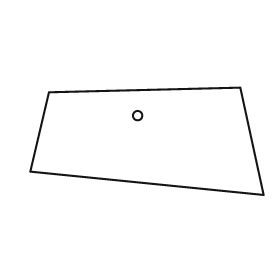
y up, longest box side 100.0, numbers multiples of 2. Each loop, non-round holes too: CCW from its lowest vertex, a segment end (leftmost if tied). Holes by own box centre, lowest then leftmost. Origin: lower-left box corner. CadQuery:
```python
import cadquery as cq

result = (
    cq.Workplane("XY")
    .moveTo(100.0, 0.0)
    .lineTo(90.0, 46.0)
    .lineTo(8.0, 44.0)
    .lineTo(0.0, 10.0)
    .close()
    .moveTo(46.0, 34.0)
    .circle(2.0)
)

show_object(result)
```